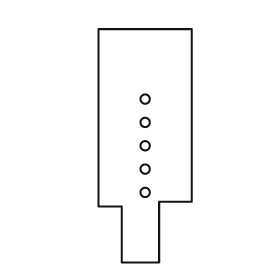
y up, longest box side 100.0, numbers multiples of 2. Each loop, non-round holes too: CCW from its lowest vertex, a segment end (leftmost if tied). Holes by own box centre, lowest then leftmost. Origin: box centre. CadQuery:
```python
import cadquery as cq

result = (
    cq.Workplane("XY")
    .moveTo(-10.0, -50.0)
    .lineTo(6.0, -50.0)
    .lineTo(6.0, -24.0)
    .lineTo(20.0, -24.0)
    .lineTo(20.0, 50.0)
    .lineTo(-20.0, 50.0)
    .lineTo(-20.0, -26.0)
    .lineTo(-10.0, -26.0)
    .close()
    .moveTo(0.0, -20.0)
    .circle(2.0)
    .moveTo(0.0, -10.0)
    .circle(2.0)
    .moveTo(0.0, 0.0)
    .circle(2.0)
    .moveTo(0.0, 10.0)
    .circle(2.0)
    .moveTo(0.0, 20.0)
    .circle(2.0)
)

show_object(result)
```